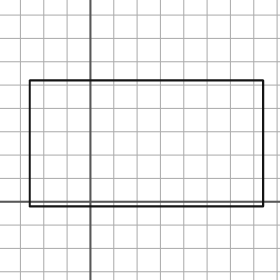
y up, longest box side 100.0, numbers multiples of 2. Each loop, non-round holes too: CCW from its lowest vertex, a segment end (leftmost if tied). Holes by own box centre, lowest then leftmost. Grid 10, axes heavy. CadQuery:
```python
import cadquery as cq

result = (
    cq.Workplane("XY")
    .moveTo(-26.0, -2.0)
    .lineTo(74.0, -2.0)
    .lineTo(74.0, 52.0)
    .lineTo(-26.0, 52.0)
    .close()
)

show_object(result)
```